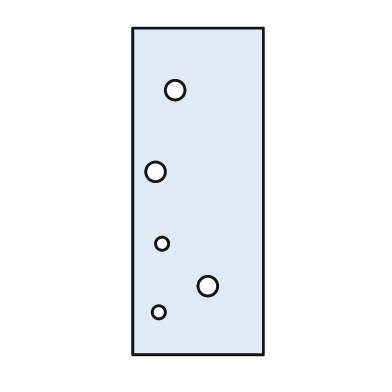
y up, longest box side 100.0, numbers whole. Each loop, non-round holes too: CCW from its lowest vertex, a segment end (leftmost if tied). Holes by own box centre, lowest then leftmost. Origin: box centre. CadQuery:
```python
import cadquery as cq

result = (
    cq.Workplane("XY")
    .moveTo(-20.0, -50.0)
    .lineTo(20.0, -50.0)
    .lineTo(20.0, 50.0)
    .lineTo(-20.0, 50.0)
    .close()
    .moveTo(-12.0, -37.0)
    .circle(2.0)
    .moveTo(3.0, -29.0)
    .circle(3.0)
    .moveTo(-11.0, -16.0)
    .circle(2.0)
    .moveTo(-13.0, 6.0)
    .circle(3.0)
    .moveTo(-7.0, 31.0)
    .circle(3.0)
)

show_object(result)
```